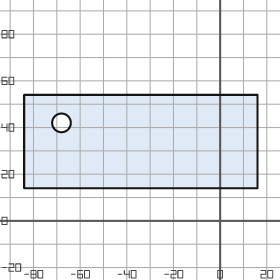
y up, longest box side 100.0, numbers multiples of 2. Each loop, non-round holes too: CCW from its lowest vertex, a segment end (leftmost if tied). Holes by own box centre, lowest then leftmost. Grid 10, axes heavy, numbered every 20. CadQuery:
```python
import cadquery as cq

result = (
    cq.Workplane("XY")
    .moveTo(-84.0, 14.0)
    .lineTo(16.0, 14.0)
    .lineTo(16.0, 54.0)
    .lineTo(-84.0, 54.0)
    .close()
    .moveTo(-68.0, 42.0)
    .circle(4.0)
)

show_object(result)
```